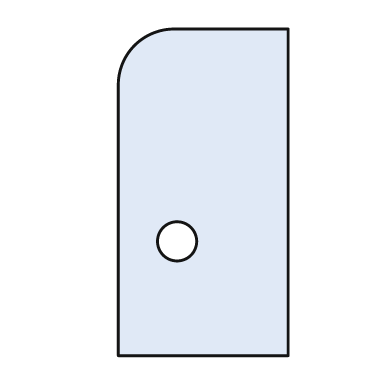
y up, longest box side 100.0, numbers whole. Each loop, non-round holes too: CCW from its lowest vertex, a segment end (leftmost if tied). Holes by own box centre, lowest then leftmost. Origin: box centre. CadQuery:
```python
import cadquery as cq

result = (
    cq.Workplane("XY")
    .moveTo(-26.0, -50.0)
    .lineTo(26.0, -50.0)
    .lineTo(26.0, 50.0)
    .lineTo(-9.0, 50.0)
    .threePointArc((-21.0, 45.0), (-26.0, 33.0))
    .close()
    .moveTo(-8.0, -15.0)
    .circle(6.0)
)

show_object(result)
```